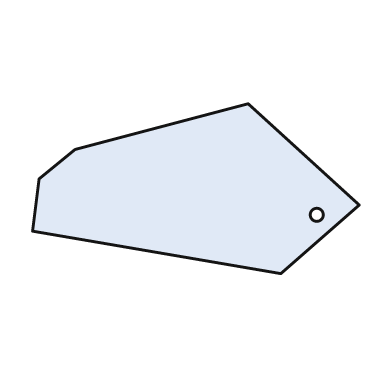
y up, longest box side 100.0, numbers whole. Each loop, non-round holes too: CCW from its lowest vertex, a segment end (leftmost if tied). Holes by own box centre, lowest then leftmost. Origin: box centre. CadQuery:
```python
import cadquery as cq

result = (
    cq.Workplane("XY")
    .moveTo(26.0, -26.0)
    .lineTo(50.0, -5.0)
    .lineTo(16.0, 26.0)
    .lineTo(-37.0, 12.0)
    .lineTo(-48.0, 3.0)
    .lineTo(-50.0, -13.0)
    .close()
    .moveTo(37.0, -8.0)
    .circle(2.0)
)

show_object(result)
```